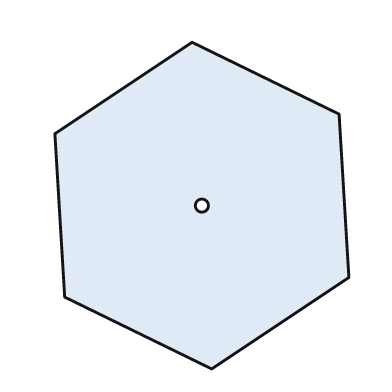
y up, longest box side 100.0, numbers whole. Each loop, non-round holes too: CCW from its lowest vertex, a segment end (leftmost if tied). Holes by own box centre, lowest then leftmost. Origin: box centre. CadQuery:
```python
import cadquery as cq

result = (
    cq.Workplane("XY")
    .moveTo(3.0, -50.0)
    .lineTo(45.0, -22.0)
    .lineTo(42.0, 28.0)
    .lineTo(-3.0, 50.0)
    .lineTo(-45.0, 22.0)
    .lineTo(-42.0, -28.0)
    .close()
    .moveTo(0.0, 0.0)
    .circle(2.0)
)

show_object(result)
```